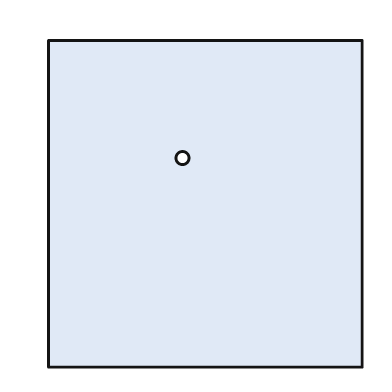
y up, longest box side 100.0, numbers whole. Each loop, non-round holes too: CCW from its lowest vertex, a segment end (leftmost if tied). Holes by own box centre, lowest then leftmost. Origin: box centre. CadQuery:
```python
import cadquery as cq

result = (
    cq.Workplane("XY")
    .moveTo(-48.0, -50.0)
    .lineTo(48.0, -50.0)
    .lineTo(48.0, 50.0)
    .lineTo(-48.0, 50.0)
    .close()
    .moveTo(-7.0, 14.0)
    .circle(2.0)
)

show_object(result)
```